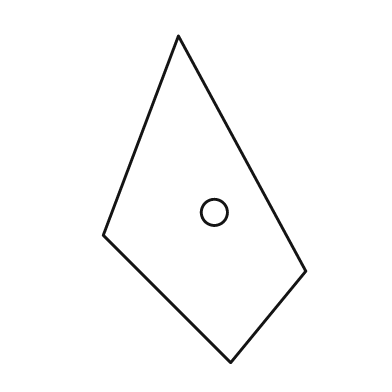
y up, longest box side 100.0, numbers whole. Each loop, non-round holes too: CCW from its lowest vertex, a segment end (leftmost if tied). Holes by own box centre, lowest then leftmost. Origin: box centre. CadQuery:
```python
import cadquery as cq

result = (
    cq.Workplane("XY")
    .moveTo(8.0, -50.0)
    .lineTo(31.0, -22.0)
    .lineTo(-8.0, 50.0)
    .lineTo(-31.0, -11.0)
    .close()
    .moveTo(3.0, -4.0)
    .circle(4.0)
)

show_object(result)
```